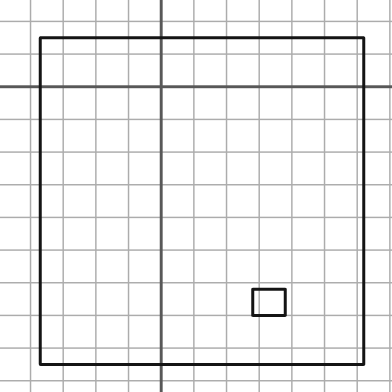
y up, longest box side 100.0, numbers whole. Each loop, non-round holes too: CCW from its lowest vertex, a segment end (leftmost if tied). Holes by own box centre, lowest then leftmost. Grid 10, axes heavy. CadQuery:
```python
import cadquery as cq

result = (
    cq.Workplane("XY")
    .moveTo(-37.0, -85.0)
    .lineTo(62.0, -85.0)
    .lineTo(62.0, 15.0)
    .lineTo(-37.0, 15.0)
    .close()
    .moveTo(28.0, -70.0)
    .lineTo(38.0, -70.0)
    .lineTo(38.0, -62.0)
    .lineTo(28.0, -62.0)
    .close()
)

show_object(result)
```